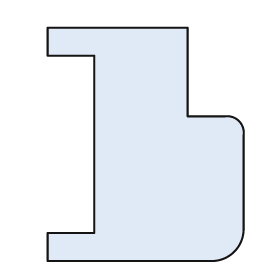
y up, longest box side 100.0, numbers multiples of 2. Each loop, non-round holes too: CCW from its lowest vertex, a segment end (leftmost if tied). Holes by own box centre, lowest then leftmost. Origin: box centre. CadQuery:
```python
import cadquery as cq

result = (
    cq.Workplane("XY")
    .moveTo(-42.0, -50.0)
    .lineTo(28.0, -50.0)
    .threePointArc((38.0, -46.0), (42.0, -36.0))
    .lineTo(42.0, 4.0)
    .threePointArc((40.0, 10.0), (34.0, 12.0))
    .lineTo(18.0, 12.0)
    .lineTo(18.0, 50.0)
    .lineTo(-42.0, 50.0)
    .lineTo(-42.0, 38.0)
    .lineTo(-22.0, 38.0)
    .lineTo(-22.0, -38.0)
    .lineTo(-42.0, -38.0)
    .close()
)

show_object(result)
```